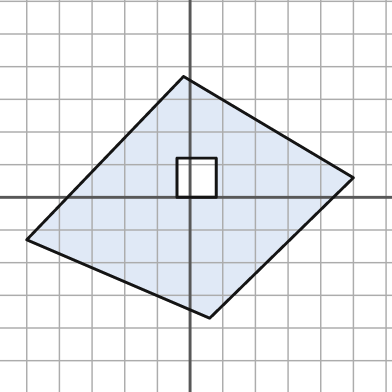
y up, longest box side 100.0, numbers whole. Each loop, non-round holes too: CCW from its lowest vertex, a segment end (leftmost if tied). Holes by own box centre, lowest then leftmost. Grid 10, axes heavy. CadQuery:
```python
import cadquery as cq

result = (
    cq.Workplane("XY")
    .moveTo(6.0, -37.0)
    .lineTo(50.0, 6.0)
    .lineTo(-2.0, 37.0)
    .lineTo(-50.0, -13.0)
    .close()
    .moveTo(-4.0, 0.0)
    .lineTo(8.0, 0.0)
    .lineTo(8.0, 12.0)
    .lineTo(-4.0, 12.0)
    .close()
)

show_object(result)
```